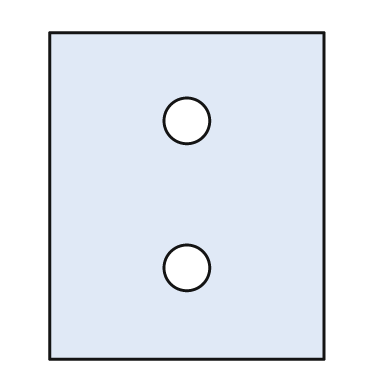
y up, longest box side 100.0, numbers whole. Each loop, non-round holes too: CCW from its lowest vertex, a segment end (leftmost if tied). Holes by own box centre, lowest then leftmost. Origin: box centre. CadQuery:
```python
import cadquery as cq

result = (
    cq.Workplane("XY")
    .moveTo(-42.0, -50.0)
    .lineTo(42.0, -50.0)
    .lineTo(42.0, 50.0)
    .lineTo(-42.0, 50.0)
    .close()
    .moveTo(0.0, -22.0)
    .circle(7.0)
    .moveTo(0.0, 23.0)
    .circle(7.0)
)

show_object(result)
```